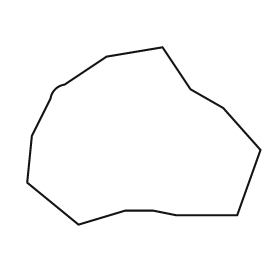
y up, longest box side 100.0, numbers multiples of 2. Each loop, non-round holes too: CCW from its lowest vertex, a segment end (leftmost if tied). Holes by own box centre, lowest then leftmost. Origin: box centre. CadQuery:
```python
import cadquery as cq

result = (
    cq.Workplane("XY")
    .moveTo(-28.0, -38.0)
    .lineTo(-8.0, -32.0)
    .lineTo(4.0, -32.0)
    .lineTo(14.0, -34.0)
    .lineTo(40.0, -34.0)
    .lineTo(50.0, -6.0)
    .lineTo(34.0, 12.0)
    .lineTo(20.0, 20.0)
    .lineTo(8.0, 38.0)
    .lineTo(-16.0, 34.0)
    .lineTo(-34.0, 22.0)
    .threePointArc((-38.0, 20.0), (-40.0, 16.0))
    .lineTo(-48.0, 0.0)
    .lineTo(-50.0, -20.0)
    .close()
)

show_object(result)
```